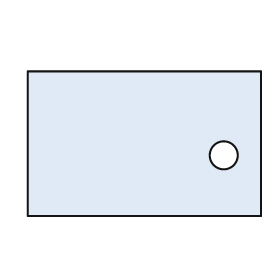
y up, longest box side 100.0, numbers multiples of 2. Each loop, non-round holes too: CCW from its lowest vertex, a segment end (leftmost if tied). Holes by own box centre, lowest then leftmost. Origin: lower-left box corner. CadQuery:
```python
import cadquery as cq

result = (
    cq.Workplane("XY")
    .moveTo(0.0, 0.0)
    .lineTo(100.0, 0.0)
    .lineTo(100.0, 62.0)
    .lineTo(0.0, 62.0)
    .close()
    .moveTo(84.0, 26.0)
    .circle(6.0)
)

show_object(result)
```